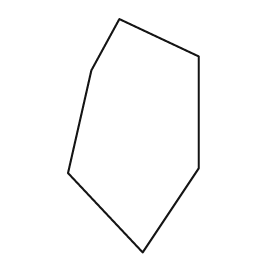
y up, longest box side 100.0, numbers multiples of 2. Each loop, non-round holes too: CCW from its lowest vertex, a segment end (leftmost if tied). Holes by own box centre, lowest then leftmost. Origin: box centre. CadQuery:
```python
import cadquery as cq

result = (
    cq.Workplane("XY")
    .moveTo(4.0, -50.0)
    .lineTo(28.0, -14.0)
    .lineTo(28.0, 34.0)
    .lineTo(-6.0, 50.0)
    .lineTo(-18.0, 28.0)
    .lineTo(-28.0, -16.0)
    .close()
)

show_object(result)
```